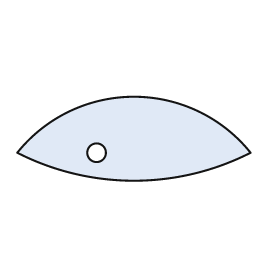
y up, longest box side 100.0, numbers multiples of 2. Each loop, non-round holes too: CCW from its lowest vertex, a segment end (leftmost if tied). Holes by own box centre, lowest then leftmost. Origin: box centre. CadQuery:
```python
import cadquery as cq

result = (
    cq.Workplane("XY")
    .moveTo(-50.0, -6.0)
    .threePointArc((0.0, -18.0), (50.0, -6.0))
    .threePointArc((0.0, 18.0), (-50.0, -6.0))
    .close()
    .moveTo(-16.0, -6.0)
    .circle(4.0)
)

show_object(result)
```